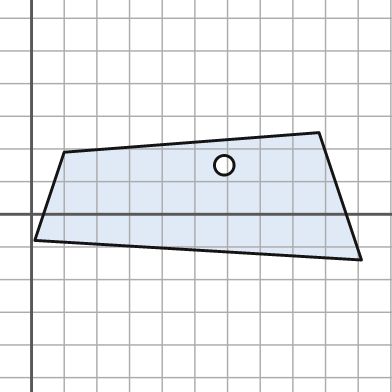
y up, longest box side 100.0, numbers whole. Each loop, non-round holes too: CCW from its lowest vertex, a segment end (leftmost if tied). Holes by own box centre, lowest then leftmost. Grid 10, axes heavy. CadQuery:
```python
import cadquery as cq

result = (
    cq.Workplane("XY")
    .moveTo(101.0, -14.0)
    .lineTo(88.0, 25.0)
    .lineTo(10.0, 19.0)
    .lineTo(1.0, -8.0)
    .close()
    .moveTo(59.0, 15.0)
    .circle(3.0)
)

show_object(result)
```